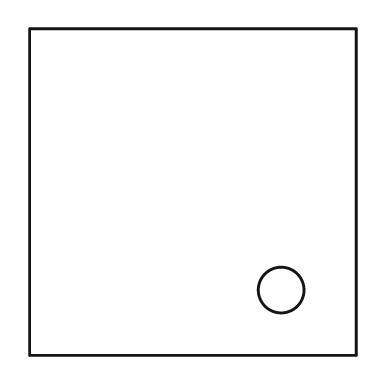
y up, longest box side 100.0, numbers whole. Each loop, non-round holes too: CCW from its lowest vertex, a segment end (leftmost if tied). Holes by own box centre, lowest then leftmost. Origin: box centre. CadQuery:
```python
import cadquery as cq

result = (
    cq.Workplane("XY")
    .moveTo(-50.0, -50.0)
    .lineTo(50.0, -50.0)
    .lineTo(50.0, 50.0)
    .lineTo(-50.0, 50.0)
    .close()
    .moveTo(27.0, -30.0)
    .circle(7.0)
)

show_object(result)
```